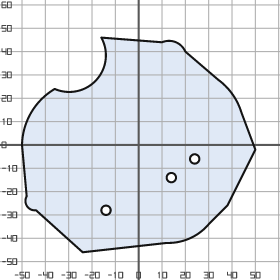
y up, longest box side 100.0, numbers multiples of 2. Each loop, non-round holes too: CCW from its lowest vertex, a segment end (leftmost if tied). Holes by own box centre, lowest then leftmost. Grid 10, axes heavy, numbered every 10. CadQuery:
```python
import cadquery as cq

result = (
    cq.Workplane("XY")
    .moveTo(-24.0, -46.0)
    .lineTo(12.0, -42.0)
    .threePointArc((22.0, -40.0), (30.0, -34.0))
    .lineTo(38.0, -26.0)
    .lineTo(50.0, -2.0)
    .lineTo(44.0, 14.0)
    .threePointArc((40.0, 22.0), (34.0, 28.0))
    .lineTo(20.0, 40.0)
    .threePointArc((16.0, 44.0), (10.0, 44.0))
    .lineTo(-16.0, 46.0)
    .threePointArc((-18.0, 28.0), (-36.0, 24.0))
    .threePointArc((-46.0, 14.0), (-50.0, 0.0))
    .lineTo(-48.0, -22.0)
    .threePointArc((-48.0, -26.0), (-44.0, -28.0))
    .close()
    .moveTo(-14.0, -28.0)
    .circle(2.0)
    .moveTo(14.0, -14.0)
    .circle(2.0)
    .moveTo(24.0, -6.0)
    .circle(2.0)
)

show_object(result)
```